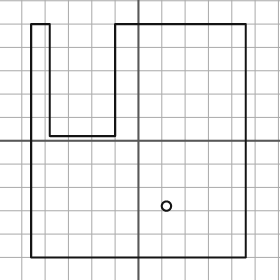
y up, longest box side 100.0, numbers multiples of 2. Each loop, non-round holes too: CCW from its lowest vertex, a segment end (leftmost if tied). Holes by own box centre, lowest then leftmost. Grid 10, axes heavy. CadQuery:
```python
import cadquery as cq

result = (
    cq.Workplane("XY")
    .moveTo(-46.0, -50.0)
    .lineTo(46.0, -50.0)
    .lineTo(46.0, 50.0)
    .lineTo(-10.0, 50.0)
    .lineTo(-10.0, 2.0)
    .lineTo(-38.0, 2.0)
    .lineTo(-38.0, 50.0)
    .lineTo(-46.0, 50.0)
    .close()
    .moveTo(12.0, -28.0)
    .circle(2.0)
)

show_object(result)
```